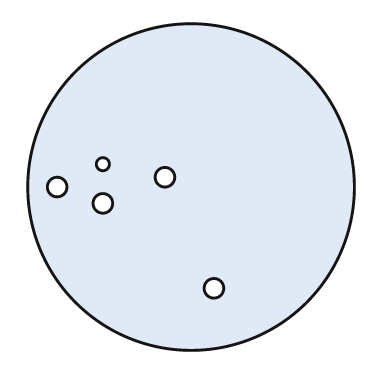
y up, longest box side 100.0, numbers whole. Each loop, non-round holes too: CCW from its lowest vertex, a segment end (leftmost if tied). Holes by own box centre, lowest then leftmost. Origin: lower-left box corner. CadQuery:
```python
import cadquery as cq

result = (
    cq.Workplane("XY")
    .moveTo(50.0, 50.0)
    .circle(50.0)
    .moveTo(57.0, 19.0)
    .circle(3.0)
    .moveTo(23.0, 45.0)
    .circle(3.0)
    .moveTo(9.0, 50.0)
    .circle(3.0)
    .moveTo(42.0, 53.0)
    .circle(3.0)
    .moveTo(23.0, 57.0)
    .circle(2.0)
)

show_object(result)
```